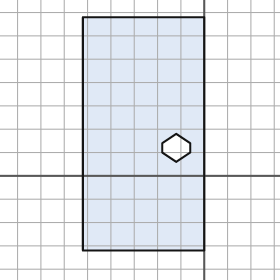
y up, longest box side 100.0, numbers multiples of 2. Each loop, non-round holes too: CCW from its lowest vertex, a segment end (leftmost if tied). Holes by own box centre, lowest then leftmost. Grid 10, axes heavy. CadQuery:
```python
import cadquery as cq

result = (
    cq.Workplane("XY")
    .moveTo(-52.0, -32.0)
    .lineTo(0.0, -32.0)
    .lineTo(0.0, 68.0)
    .lineTo(-52.0, 68.0)
    .close()
    .moveTo(-12.0, 6.0)
    .lineTo(-6.0, 10.0)
    .lineTo(-6.0, 14.0)
    .lineTo(-12.0, 18.0)
    .lineTo(-18.0, 14.0)
    .lineTo(-18.0, 10.0)
    .close()
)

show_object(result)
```